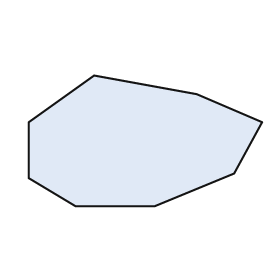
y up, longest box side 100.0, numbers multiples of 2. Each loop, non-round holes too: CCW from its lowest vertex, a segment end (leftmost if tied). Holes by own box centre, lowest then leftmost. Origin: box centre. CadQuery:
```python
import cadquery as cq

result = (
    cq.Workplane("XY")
    .moveTo(-30.0, -28.0)
    .lineTo(4.0, -28.0)
    .lineTo(38.0, -14.0)
    .lineTo(50.0, 8.0)
    .lineTo(22.0, 20.0)
    .lineTo(-22.0, 28.0)
    .lineTo(-50.0, 8.0)
    .lineTo(-50.0, -16.0)
    .close()
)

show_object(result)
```